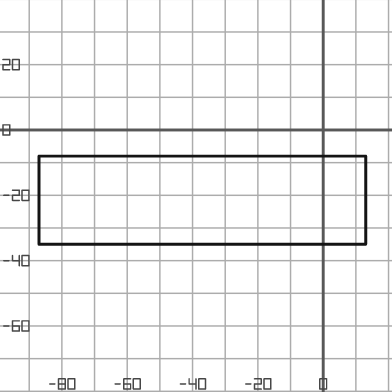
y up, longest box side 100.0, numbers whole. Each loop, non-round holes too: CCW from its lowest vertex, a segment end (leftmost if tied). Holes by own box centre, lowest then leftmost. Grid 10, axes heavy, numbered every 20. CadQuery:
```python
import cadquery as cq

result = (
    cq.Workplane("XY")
    .moveTo(-87.0, -35.0)
    .lineTo(13.0, -35.0)
    .lineTo(13.0, -8.0)
    .lineTo(-87.0, -8.0)
    .close()
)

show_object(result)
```